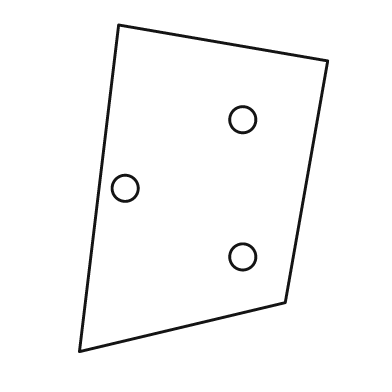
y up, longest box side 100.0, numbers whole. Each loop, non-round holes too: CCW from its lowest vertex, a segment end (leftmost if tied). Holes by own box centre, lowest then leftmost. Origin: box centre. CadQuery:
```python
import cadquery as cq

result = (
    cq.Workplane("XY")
    .moveTo(-38.0, -50.0)
    .lineTo(25.0, -35.0)
    .lineTo(38.0, 39.0)
    .lineTo(-26.0, 50.0)
    .close()
    .moveTo(12.0, -21.0)
    .circle(4.0)
    .moveTo(-24.0, 0.0)
    .circle(4.0)
    .moveTo(12.0, 21.0)
    .circle(4.0)
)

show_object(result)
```